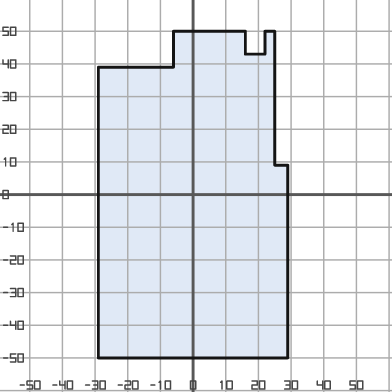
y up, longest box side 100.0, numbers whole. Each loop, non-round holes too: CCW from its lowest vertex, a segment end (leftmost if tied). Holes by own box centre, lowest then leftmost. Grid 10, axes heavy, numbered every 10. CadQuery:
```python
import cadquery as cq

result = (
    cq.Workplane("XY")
    .moveTo(-29.0, -50.0)
    .lineTo(29.0, -50.0)
    .lineTo(29.0, 9.0)
    .lineTo(25.0, 9.0)
    .lineTo(25.0, 50.0)
    .lineTo(22.0, 50.0)
    .lineTo(22.0, 43.0)
    .lineTo(16.0, 43.0)
    .lineTo(16.0, 50.0)
    .lineTo(-6.0, 50.0)
    .lineTo(-6.0, 39.0)
    .lineTo(-29.0, 39.0)
    .close()
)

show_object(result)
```